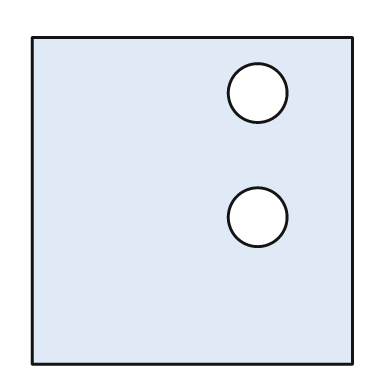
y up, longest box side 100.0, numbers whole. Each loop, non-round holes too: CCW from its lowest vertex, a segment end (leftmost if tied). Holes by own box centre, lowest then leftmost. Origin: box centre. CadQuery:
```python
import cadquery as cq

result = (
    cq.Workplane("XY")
    .moveTo(-49.0, -50.0)
    .lineTo(49.0, -50.0)
    .lineTo(49.0, 50.0)
    .lineTo(-49.0, 50.0)
    .close()
    .moveTo(20.0, -5.0)
    .circle(9.0)
    .moveTo(20.0, 33.0)
    .circle(9.0)
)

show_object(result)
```